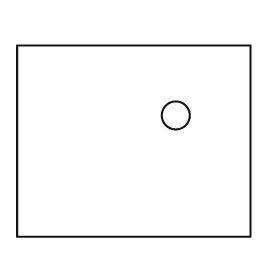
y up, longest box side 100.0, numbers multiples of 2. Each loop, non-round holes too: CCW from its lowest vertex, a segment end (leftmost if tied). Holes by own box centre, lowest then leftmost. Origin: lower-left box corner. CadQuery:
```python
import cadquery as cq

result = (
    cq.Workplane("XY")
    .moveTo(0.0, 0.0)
    .lineTo(100.0, 0.0)
    .lineTo(100.0, 82.0)
    .lineTo(0.0, 82.0)
    .close()
    .moveTo(68.0, 52.0)
    .circle(6.0)
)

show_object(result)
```